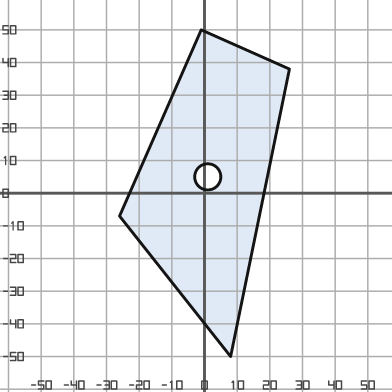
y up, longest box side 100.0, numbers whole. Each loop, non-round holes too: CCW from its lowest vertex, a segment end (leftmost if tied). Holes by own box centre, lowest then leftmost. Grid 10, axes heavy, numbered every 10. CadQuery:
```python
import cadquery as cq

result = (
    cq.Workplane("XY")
    .moveTo(8.0, -50.0)
    .lineTo(26.0, 38.0)
    .lineTo(-1.0, 50.0)
    .lineTo(-26.0, -7.0)
    .close()
    .moveTo(1.0, 5.0)
    .circle(4.0)
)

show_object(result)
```